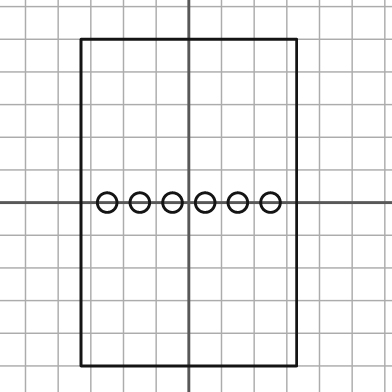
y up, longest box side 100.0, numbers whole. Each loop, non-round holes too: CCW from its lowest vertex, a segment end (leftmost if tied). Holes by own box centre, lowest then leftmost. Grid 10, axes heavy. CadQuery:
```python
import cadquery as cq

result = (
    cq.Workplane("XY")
    .moveTo(-33.0, -50.0)
    .lineTo(33.0, -50.0)
    .lineTo(33.0, 50.0)
    .lineTo(-33.0, 50.0)
    .close()
    .moveTo(-25.0, 0.0)
    .circle(3.0)
    .moveTo(-15.0, 0.0)
    .circle(3.0)
    .moveTo(-5.0, 0.0)
    .circle(3.0)
    .moveTo(5.0, 0.0)
    .circle(3.0)
    .moveTo(15.0, 0.0)
    .circle(3.0)
    .moveTo(25.0, 0.0)
    .circle(3.0)
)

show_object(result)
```